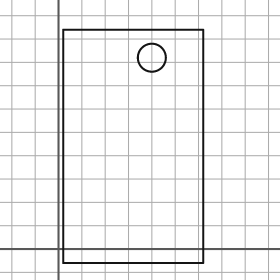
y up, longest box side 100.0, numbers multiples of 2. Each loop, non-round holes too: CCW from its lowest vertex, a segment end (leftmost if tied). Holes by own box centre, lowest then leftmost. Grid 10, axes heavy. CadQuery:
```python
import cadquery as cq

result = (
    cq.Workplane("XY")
    .moveTo(2.0, -6.0)
    .lineTo(62.0, -6.0)
    .lineTo(62.0, 94.0)
    .lineTo(2.0, 94.0)
    .close()
    .moveTo(40.0, 82.0)
    .circle(6.0)
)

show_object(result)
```